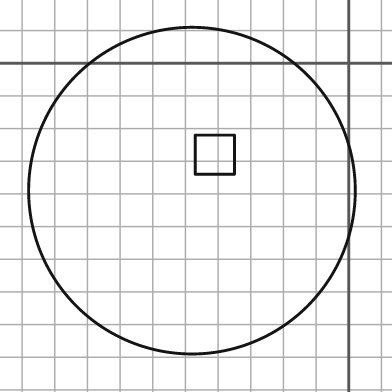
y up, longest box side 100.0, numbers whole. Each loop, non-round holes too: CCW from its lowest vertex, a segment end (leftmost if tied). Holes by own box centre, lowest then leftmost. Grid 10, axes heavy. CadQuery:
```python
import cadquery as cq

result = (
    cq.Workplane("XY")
    .moveTo(-48.0, -39.0)
    .circle(50.0)
    .moveTo(-47.0, -34.0)
    .lineTo(-35.0, -34.0)
    .lineTo(-35.0, -22.0)
    .lineTo(-47.0, -22.0)
    .close()
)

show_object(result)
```